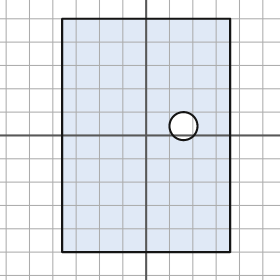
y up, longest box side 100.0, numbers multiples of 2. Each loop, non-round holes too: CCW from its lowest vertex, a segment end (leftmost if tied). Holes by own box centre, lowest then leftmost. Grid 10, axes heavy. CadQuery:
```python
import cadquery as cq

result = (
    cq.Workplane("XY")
    .moveTo(-36.0, -50.0)
    .lineTo(36.0, -50.0)
    .lineTo(36.0, 50.0)
    .lineTo(-36.0, 50.0)
    .close()
    .moveTo(16.0, 4.0)
    .circle(6.0)
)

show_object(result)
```